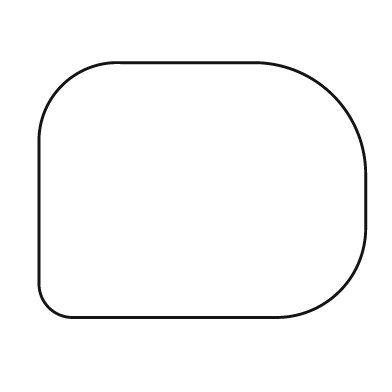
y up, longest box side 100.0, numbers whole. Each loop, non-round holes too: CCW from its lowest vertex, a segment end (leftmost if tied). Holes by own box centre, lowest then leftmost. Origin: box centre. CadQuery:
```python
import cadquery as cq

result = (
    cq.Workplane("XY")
    .moveTo(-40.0, -39.0)
    .lineTo(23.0, -39.0)
    .threePointArc((42.0, -31.0), (50.0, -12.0))
    .lineTo(50.0, 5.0)
    .threePointArc((40.0, 29.0), (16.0, 39.0))
    .lineTo(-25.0, 39.0)
    .threePointArc((-43.0, 32.0), (-50.0, 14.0))
    .lineTo(-50.0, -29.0)
    .threePointArc((-47.0, -36.0), (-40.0, -39.0))
    .close()
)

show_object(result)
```